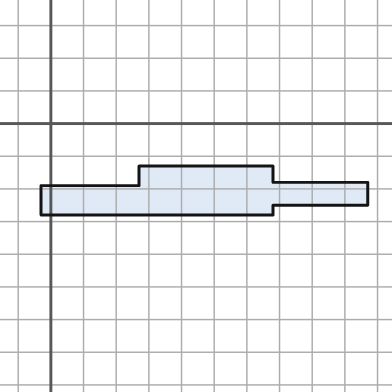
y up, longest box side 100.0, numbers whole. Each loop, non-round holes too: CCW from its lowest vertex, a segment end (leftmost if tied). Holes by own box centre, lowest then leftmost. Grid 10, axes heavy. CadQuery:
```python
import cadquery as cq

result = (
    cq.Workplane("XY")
    .moveTo(-3.0, -28.0)
    .lineTo(68.0, -28.0)
    .lineTo(68.0, -25.0)
    .lineTo(97.0, -25.0)
    .lineTo(97.0, -18.0)
    .lineTo(68.0, -18.0)
    .lineTo(68.0, -13.0)
    .lineTo(27.0, -13.0)
    .lineTo(27.0, -19.0)
    .lineTo(-3.0, -19.0)
    .close()
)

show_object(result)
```